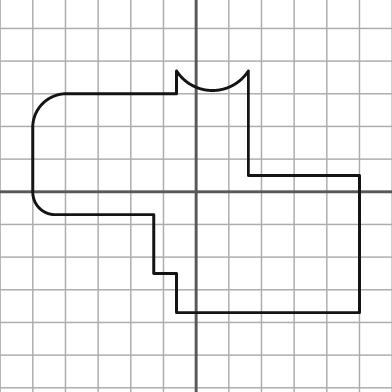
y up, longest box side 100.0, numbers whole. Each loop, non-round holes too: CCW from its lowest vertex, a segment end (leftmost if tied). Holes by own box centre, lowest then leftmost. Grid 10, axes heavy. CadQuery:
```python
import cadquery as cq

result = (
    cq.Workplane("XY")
    .moveTo(-6.0, -37.0)
    .lineTo(50.0, -37.0)
    .lineTo(50.0, 5.0)
    .lineTo(16.0, 5.0)
    .lineTo(16.0, 37.0)
    .threePointArc((5.0, 31.0), (-6.0, 37.0))
    .lineTo(-6.0, 30.0)
    .lineTo(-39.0, 30.0)
    .threePointArc((-47.0, 27.0), (-50.0, 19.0))
    .lineTo(-50.0, 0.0)
    .threePointArc((-48.0, -5.0), (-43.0, -7.0))
    .lineTo(-13.0, -7.0)
    .lineTo(-13.0, -25.0)
    .lineTo(-6.0, -25.0)
    .close()
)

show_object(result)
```